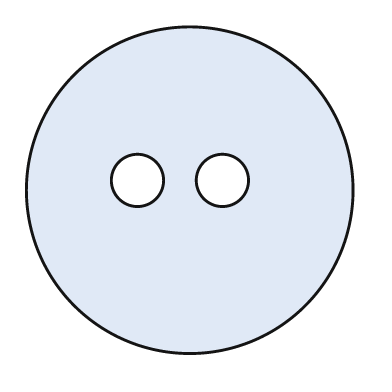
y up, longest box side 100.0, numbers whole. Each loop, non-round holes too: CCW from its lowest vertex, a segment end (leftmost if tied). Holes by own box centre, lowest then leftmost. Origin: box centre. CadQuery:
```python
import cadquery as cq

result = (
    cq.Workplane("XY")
    .moveTo(0.0, 0.0)
    .circle(50.0)
    .moveTo(-16.0, 3.0)
    .circle(8.0)
    .moveTo(10.0, 3.0)
    .circle(8.0)
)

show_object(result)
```